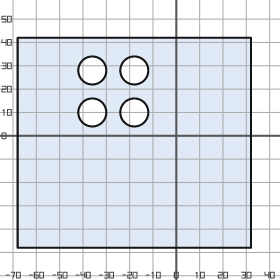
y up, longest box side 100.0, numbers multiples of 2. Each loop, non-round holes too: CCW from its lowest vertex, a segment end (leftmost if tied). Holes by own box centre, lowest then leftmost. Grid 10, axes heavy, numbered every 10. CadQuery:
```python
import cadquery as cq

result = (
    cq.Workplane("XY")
    .moveTo(-68.0, -48.0)
    .lineTo(32.0, -48.0)
    .lineTo(32.0, 42.0)
    .lineTo(-68.0, 42.0)
    .close()
    .moveTo(-36.0, 10.0)
    .circle(6.0)
    .moveTo(-18.0, 10.0)
    .circle(6.0)
    .moveTo(-36.0, 28.0)
    .circle(6.0)
    .moveTo(-18.0, 28.0)
    .circle(6.0)
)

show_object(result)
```